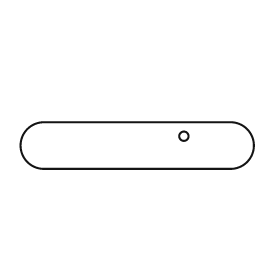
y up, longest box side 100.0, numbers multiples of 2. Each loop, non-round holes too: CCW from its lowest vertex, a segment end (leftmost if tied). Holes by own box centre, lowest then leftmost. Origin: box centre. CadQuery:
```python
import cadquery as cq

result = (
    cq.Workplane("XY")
    .moveTo(-40.0, -10.0)
    .lineTo(40.0, -10.0)
    .threePointArc((50.0, 0.0), (40.0, 10.0))
    .lineTo(-40.0, 10.0)
    .threePointArc((-50.0, 0.0), (-40.0, -10.0))
    .close()
    .moveTo(20.0, 4.0)
    .circle(2.0)
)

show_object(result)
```